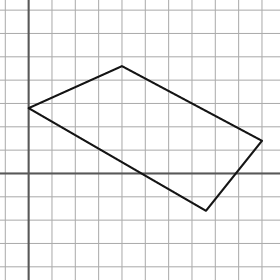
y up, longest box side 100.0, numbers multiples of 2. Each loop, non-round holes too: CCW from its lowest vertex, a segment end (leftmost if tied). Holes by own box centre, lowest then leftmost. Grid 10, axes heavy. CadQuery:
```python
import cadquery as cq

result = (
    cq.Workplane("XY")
    .moveTo(76.0, -16.0)
    .lineTo(100.0, 14.0)
    .lineTo(40.0, 46.0)
    .lineTo(0.0, 28.0)
    .close()
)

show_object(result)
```